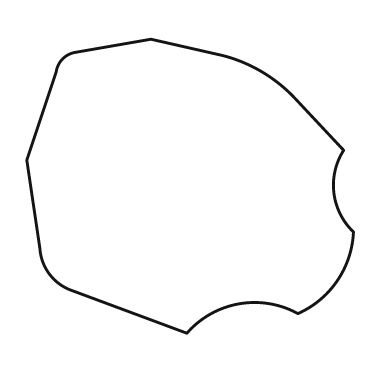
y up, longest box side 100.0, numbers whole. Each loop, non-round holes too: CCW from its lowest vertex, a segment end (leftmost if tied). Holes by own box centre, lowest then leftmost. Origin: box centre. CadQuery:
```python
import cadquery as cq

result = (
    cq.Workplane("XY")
    .moveTo(-1.0, -45.0)
    .threePointArc((15.0, -36.0), (33.0, -39.0))
    .threePointArc((45.0, -29.0), (50.0, -14.0))
    .threePointArc((44.0, -2.0), (47.0, 11.0))
    .lineTo(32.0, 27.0)
    .threePointArc((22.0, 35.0), (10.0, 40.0))
    .lineTo(-12.0, 45.0)
    .lineTo(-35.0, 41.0)
    .threePointArc((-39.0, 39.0), (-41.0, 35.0))
    .lineTo(-50.0, 8.0)
    .lineTo(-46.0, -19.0)
    .threePointArc((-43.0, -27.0), (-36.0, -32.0))
    .close()
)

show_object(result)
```